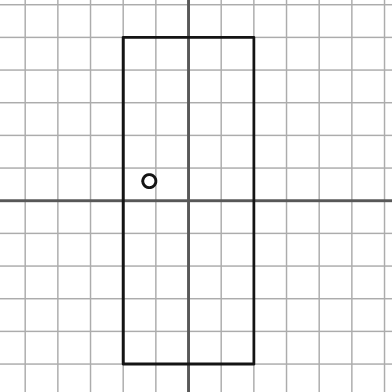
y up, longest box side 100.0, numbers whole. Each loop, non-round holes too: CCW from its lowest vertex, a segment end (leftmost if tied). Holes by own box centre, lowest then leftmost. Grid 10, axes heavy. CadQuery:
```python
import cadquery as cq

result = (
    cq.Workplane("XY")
    .moveTo(-20.0, -50.0)
    .lineTo(20.0, -50.0)
    .lineTo(20.0, 50.0)
    .lineTo(-20.0, 50.0)
    .close()
    .moveTo(-12.0, 6.0)
    .circle(2.0)
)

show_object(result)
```